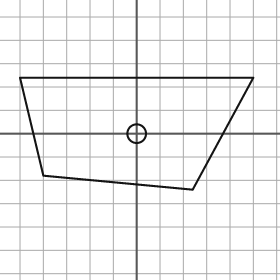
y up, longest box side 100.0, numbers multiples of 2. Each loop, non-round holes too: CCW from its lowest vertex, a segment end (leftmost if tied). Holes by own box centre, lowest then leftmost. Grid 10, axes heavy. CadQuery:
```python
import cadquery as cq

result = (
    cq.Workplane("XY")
    .moveTo(24.0, -24.0)
    .lineTo(50.0, 24.0)
    .lineTo(-50.0, 24.0)
    .lineTo(-40.0, -18.0)
    .close()
    .moveTo(0.0, 0.0)
    .circle(4.0)
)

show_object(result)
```